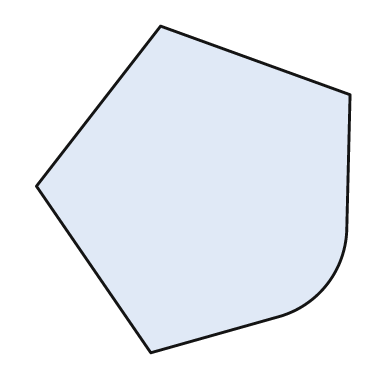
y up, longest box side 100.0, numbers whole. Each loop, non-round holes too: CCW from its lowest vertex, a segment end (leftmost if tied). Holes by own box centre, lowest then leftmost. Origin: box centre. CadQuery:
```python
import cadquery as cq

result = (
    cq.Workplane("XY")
    .moveTo(-13.0, -50.0)
    .lineTo(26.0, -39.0)
    .threePointArc((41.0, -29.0), (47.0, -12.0))
    .lineTo(48.0, 29.0)
    .lineTo(-10.0, 50.0)
    .lineTo(-48.0, 1.0)
    .close()
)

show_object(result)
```